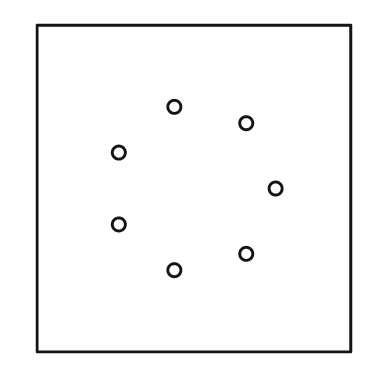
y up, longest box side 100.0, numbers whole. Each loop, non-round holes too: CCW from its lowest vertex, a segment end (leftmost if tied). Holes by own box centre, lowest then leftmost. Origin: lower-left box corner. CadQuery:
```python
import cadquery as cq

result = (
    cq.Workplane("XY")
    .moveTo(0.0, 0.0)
    .lineTo(96.0, 0.0)
    .lineTo(96.0, 100.0)
    .lineTo(0.0, 100.0)
    .close()
    .moveTo(42.0, 25.0)
    .circle(2.0)
    .moveTo(64.0, 30.0)
    .circle(2.0)
    .moveTo(25.0, 39.0)
    .circle(2.0)
    .moveTo(73.0, 50.0)
    .circle(2.0)
    .moveTo(25.0, 61.0)
    .circle(2.0)
    .moveTo(64.0, 70.0)
    .circle(2.0)
    .moveTo(42.0, 75.0)
    .circle(2.0)
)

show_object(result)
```